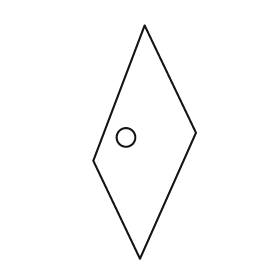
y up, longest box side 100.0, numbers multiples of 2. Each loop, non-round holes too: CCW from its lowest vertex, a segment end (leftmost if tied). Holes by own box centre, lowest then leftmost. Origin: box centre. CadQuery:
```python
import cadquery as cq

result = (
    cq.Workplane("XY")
    .moveTo(-2.0, -50.0)
    .lineTo(22.0, 4.0)
    .lineTo(0.0, 50.0)
    .lineTo(-22.0, -8.0)
    .close()
    .moveTo(-8.0, 2.0)
    .circle(4.0)
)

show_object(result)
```